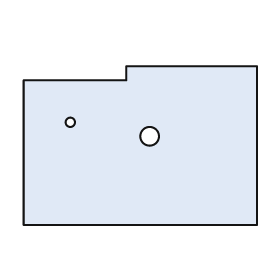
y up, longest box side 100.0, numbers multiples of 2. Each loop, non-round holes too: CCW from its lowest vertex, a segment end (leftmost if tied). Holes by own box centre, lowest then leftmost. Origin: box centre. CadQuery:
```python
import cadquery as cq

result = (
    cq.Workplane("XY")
    .moveTo(-50.0, -34.0)
    .lineTo(50.0, -34.0)
    .lineTo(50.0, 34.0)
    .lineTo(-6.0, 34.0)
    .lineTo(-6.0, 28.0)
    .lineTo(-50.0, 28.0)
    .close()
    .moveTo(4.0, 4.0)
    .circle(4.0)
    .moveTo(-30.0, 10.0)
    .circle(2.0)
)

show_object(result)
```